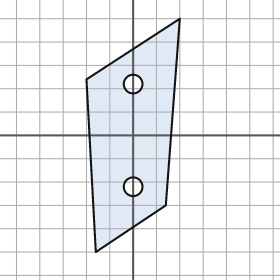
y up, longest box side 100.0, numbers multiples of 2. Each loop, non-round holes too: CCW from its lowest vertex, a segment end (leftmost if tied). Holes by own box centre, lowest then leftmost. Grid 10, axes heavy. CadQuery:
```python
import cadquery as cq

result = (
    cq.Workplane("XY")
    .moveTo(-16.0, -50.0)
    .lineTo(14.0, -30.0)
    .lineTo(20.0, 50.0)
    .lineTo(-20.0, 24.0)
    .close()
    .moveTo(0.0, -22.0)
    .circle(4.0)
    .moveTo(0.0, 22.0)
    .circle(4.0)
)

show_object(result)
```